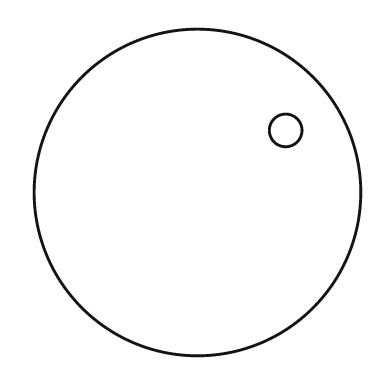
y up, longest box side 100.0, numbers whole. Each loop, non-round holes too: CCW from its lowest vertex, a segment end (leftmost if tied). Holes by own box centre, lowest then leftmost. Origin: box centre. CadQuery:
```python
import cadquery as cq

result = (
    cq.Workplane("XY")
    .moveTo(0.0, 0.0)
    .circle(50.0)
    .moveTo(27.0, 19.0)
    .circle(5.0)
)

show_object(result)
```